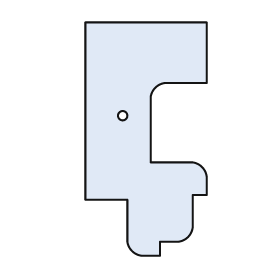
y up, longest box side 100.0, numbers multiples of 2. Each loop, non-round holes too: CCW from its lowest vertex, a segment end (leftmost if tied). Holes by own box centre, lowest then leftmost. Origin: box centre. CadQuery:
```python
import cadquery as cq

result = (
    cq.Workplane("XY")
    .moveTo(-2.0, -50.0)
    .lineTo(6.0, -50.0)
    .lineTo(6.0, -44.0)
    .lineTo(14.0, -44.0)
    .threePointArc((18.0, -42.0), (20.0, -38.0))
    .lineTo(20.0, -24.0)
    .lineTo(26.0, -24.0)
    .lineTo(26.0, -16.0)
    .threePointArc((24.0, -12.0), (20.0, -10.0))
    .lineTo(2.0, -10.0)
    .lineTo(2.0, 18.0)
    .threePointArc((4.0, 22.0), (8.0, 24.0))
    .lineTo(26.0, 24.0)
    .lineTo(26.0, 50.0)
    .lineTo(-26.0, 50.0)
    .lineTo(-26.0, -26.0)
    .lineTo(-8.0, -26.0)
    .lineTo(-8.0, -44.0)
    .threePointArc((-6.0, -48.0), (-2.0, -50.0))
    .close()
    .moveTo(-10.0, 10.0)
    .circle(2.0)
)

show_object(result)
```